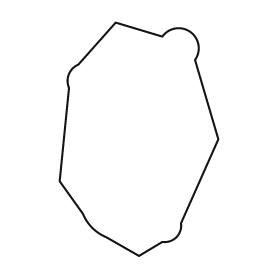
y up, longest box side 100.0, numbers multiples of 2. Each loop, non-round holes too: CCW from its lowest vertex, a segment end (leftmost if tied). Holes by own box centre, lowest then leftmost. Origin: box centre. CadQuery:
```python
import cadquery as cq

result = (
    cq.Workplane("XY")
    .moveTo(0.0, -50.0)
    .lineTo(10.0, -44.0)
    .threePointArc((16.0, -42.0), (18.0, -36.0))
    .lineTo(34.0, 0.0)
    .lineTo(24.0, 34.0)
    .threePointArc((22.0, 46.0), (10.0, 44.0))
    .lineTo(-10.0, 50.0)
    .lineTo(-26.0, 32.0)
    .threePointArc((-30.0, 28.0), (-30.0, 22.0))
    .lineTo(-34.0, -18.0)
    .lineTo(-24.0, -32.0)
    .threePointArc((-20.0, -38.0), (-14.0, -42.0))
    .close()
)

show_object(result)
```